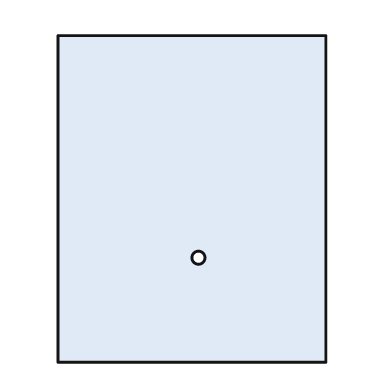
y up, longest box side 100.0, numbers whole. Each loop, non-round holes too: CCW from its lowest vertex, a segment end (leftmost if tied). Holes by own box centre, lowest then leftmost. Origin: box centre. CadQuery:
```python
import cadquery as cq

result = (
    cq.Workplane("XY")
    .moveTo(-41.0, -50.0)
    .lineTo(41.0, -50.0)
    .lineTo(41.0, 50.0)
    .lineTo(-41.0, 50.0)
    .close()
    .moveTo(2.0, -18.0)
    .circle(2.0)
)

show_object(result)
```